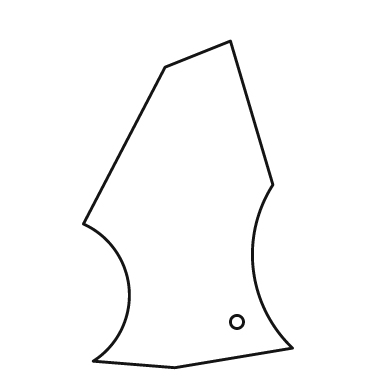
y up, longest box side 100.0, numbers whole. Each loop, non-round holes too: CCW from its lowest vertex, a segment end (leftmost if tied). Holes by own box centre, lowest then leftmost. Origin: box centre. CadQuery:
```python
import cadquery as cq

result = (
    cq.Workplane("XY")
    .moveTo(-4.0, -50.0)
    .lineTo(32.0, -44.0)
    .threePointArc((20.0, -20.0), (26.0, 6.0))
    .lineTo(13.0, 50.0)
    .lineTo(-7.0, 42.0)
    .lineTo(-32.0, -6.0)
    .threePointArc((-18.0, -26.0), (-29.0, -48.0))
    .close()
    .moveTo(15.0, -36.0)
    .circle(2.0)
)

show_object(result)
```